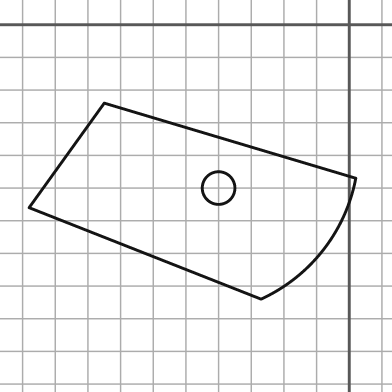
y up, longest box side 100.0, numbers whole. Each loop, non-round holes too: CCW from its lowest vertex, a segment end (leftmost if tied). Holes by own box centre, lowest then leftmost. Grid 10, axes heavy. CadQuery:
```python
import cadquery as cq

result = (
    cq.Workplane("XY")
    .moveTo(-27.0, -84.0)
    .threePointArc((-8.0, -69.0), (2.0, -47.0))
    .lineTo(-75.0, -24.0)
    .lineTo(-98.0, -56.0)
    .close()
    .moveTo(-40.0, -50.0)
    .circle(5.0)
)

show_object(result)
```